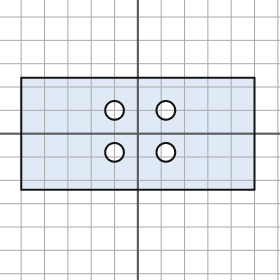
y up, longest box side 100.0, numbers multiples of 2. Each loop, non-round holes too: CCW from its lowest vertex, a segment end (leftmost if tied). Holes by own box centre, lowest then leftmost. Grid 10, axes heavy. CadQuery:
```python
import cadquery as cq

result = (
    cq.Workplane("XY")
    .moveTo(-50.0, -24.0)
    .lineTo(50.0, -24.0)
    .lineTo(50.0, 24.0)
    .lineTo(-50.0, 24.0)
    .close()
    .moveTo(-10.0, -8.0)
    .circle(4.0)
    .moveTo(12.0, -8.0)
    .circle(4.0)
    .moveTo(-10.0, 10.0)
    .circle(4.0)
    .moveTo(12.0, 10.0)
    .circle(4.0)
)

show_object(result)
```